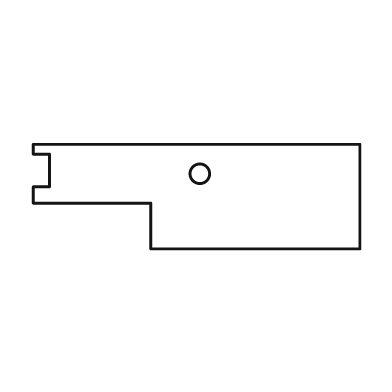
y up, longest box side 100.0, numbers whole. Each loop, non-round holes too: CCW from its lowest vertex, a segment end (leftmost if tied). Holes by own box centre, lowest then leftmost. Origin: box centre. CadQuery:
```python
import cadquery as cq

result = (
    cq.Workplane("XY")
    .moveTo(-14.0, -16.0)
    .lineTo(50.0, -16.0)
    .lineTo(50.0, 16.0)
    .lineTo(-50.0, 16.0)
    .lineTo(-50.0, 13.0)
    .lineTo(-45.0, 13.0)
    .lineTo(-45.0, 3.0)
    .lineTo(-50.0, 3.0)
    .lineTo(-50.0, -2.0)
    .lineTo(-14.0, -2.0)
    .close()
    .moveTo(1.0, 7.0)
    .circle(3.0)
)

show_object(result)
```